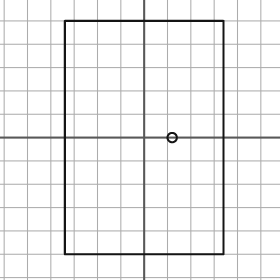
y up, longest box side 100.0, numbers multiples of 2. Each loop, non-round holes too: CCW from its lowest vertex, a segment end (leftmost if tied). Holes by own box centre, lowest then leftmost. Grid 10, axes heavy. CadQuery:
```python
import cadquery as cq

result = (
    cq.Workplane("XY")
    .moveTo(-34.0, -50.0)
    .lineTo(34.0, -50.0)
    .lineTo(34.0, 50.0)
    .lineTo(-34.0, 50.0)
    .close()
    .moveTo(12.0, 0.0)
    .circle(2.0)
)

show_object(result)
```